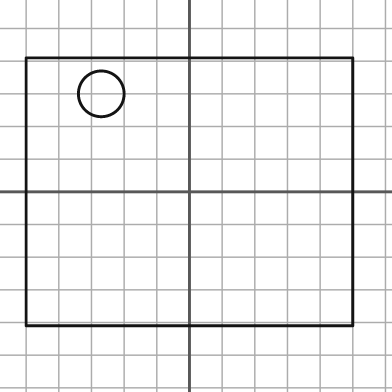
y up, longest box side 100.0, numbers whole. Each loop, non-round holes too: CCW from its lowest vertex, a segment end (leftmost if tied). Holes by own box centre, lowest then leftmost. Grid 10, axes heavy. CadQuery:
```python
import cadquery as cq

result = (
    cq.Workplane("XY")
    .moveTo(-50.0, -41.0)
    .lineTo(50.0, -41.0)
    .lineTo(50.0, 41.0)
    .lineTo(-50.0, 41.0)
    .close()
    .moveTo(-27.0, 30.0)
    .circle(7.0)
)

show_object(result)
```